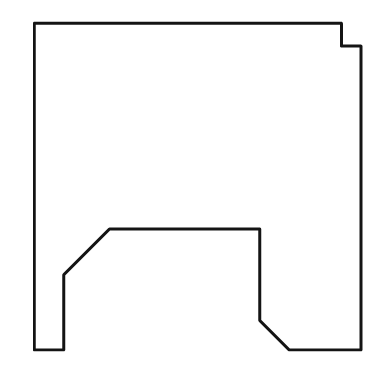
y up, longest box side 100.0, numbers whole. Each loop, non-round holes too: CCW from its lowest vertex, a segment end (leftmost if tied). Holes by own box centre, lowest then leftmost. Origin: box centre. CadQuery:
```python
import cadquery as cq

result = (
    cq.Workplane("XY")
    .moveTo(-50.0, -50.0)
    .lineTo(-41.0, -50.0)
    .lineTo(-41.0, -27.0)
    .lineTo(-27.0, -13.0)
    .lineTo(19.0, -13.0)
    .lineTo(19.0, -41.0)
    .lineTo(28.0, -50.0)
    .lineTo(50.0, -50.0)
    .lineTo(50.0, 43.0)
    .lineTo(44.0, 43.0)
    .lineTo(44.0, 50.0)
    .lineTo(-50.0, 50.0)
    .close()
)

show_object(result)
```